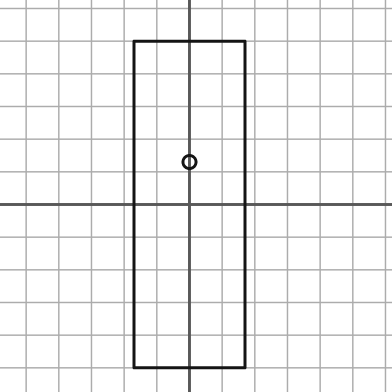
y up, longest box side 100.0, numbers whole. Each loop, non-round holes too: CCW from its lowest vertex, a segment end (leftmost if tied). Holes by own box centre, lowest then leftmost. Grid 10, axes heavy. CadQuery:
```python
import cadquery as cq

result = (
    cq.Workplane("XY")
    .moveTo(-17.0, -50.0)
    .lineTo(17.0, -50.0)
    .lineTo(17.0, 50.0)
    .lineTo(-17.0, 50.0)
    .close()
    .moveTo(0.0, 13.0)
    .circle(2.0)
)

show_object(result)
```